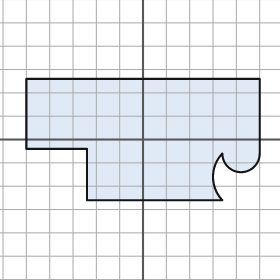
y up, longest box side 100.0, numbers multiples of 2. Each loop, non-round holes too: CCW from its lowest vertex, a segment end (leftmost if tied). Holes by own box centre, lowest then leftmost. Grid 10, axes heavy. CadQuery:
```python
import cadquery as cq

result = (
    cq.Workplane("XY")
    .moveTo(-24.0, -26.0)
    .lineTo(34.0, -26.0)
    .threePointArc((30.0, -16.0), (34.0, -6.0))
    .threePointArc((42.0, -14.0), (50.0, -6.0))
    .lineTo(50.0, 26.0)
    .lineTo(-50.0, 26.0)
    .lineTo(-50.0, -4.0)
    .lineTo(-24.0, -4.0)
    .close()
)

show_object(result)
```